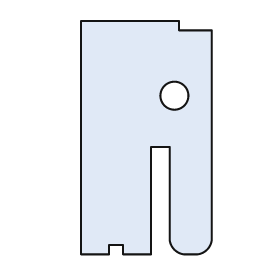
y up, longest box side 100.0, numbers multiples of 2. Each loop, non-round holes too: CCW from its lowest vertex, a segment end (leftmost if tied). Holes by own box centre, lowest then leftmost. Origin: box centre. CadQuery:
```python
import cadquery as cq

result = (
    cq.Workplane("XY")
    .moveTo(-28.0, -50.0)
    .lineTo(-16.0, -50.0)
    .lineTo(-16.0, -46.0)
    .lineTo(-10.0, -46.0)
    .lineTo(-10.0, -50.0)
    .lineTo(2.0, -50.0)
    .lineTo(2.0, -4.0)
    .lineTo(10.0, -4.0)
    .lineTo(10.0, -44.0)
    .threePointArc((12.0, -48.0), (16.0, -50.0))
    .lineTo(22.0, -50.0)
    .threePointArc((26.0, -48.0), (28.0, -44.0))
    .lineTo(28.0, 46.0)
    .lineTo(14.0, 46.0)
    .lineTo(14.0, 50.0)
    .lineTo(-28.0, 50.0)
    .close()
    .moveTo(12.0, 18.0)
    .circle(6.0)
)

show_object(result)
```